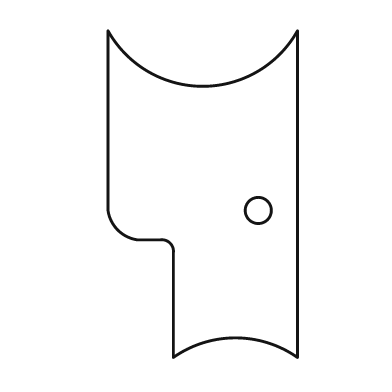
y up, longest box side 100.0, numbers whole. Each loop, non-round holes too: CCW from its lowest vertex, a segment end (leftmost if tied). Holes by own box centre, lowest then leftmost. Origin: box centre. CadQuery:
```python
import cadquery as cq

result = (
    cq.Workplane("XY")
    .moveTo(-9.0, -50.0)
    .threePointArc((10.0, -44.0), (29.0, -50.0))
    .lineTo(29.0, 50.0)
    .threePointArc((0.0, 33.0), (-29.0, 50.0))
    .lineTo(-29.0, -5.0)
    .threePointArc((-26.0, -11.0), (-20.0, -14.0))
    .lineTo(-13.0, -14.0)
    .threePointArc((-10.0, -15.0), (-9.0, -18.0))
    .close()
    .moveTo(17.0, -5.0)
    .circle(4.0)
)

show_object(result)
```